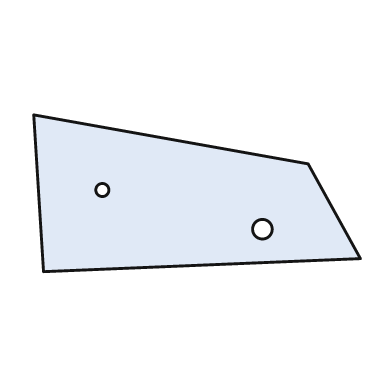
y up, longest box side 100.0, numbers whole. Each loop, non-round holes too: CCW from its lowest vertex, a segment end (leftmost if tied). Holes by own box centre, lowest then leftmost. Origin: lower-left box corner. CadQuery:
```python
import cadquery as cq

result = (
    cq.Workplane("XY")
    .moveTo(3.0, 0.0)
    .lineTo(100.0, 4.0)
    .lineTo(84.0, 33.0)
    .lineTo(0.0, 48.0)
    .close()
    .moveTo(70.0, 13.0)
    .circle(3.0)
    .moveTo(21.0, 25.0)
    .circle(2.0)
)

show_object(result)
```